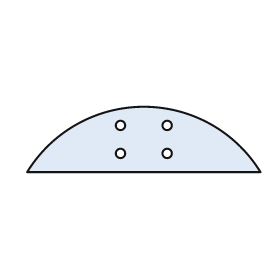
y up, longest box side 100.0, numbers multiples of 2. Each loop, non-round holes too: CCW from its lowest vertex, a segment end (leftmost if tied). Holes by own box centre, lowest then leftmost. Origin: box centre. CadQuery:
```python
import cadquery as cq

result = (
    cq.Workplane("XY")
    .moveTo(-50.0, -14.0)
    .lineTo(50.0, -14.0)
    .threePointArc((0.0, 14.0), (-50.0, -14.0))
    .close()
    .moveTo(-10.0, -6.0)
    .circle(2.0)
    .moveTo(10.0, -6.0)
    .circle(2.0)
    .moveTo(-10.0, 6.0)
    .circle(2.0)
    .moveTo(10.0, 6.0)
    .circle(2.0)
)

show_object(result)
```